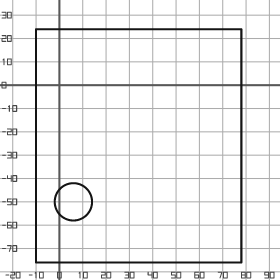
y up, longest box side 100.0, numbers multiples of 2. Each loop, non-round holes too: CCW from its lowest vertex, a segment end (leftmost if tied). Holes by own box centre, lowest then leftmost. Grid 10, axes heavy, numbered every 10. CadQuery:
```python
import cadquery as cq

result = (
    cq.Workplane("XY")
    .moveTo(-10.0, -76.0)
    .lineTo(78.0, -76.0)
    .lineTo(78.0, 24.0)
    .lineTo(-10.0, 24.0)
    .close()
    .moveTo(6.0, -50.0)
    .circle(8.0)
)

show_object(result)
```